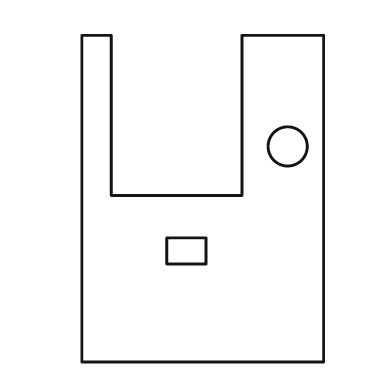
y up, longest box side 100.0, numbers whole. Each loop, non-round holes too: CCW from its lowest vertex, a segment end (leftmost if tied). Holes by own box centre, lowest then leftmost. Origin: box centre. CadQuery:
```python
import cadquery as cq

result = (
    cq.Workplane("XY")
    .moveTo(-37.0, -50.0)
    .lineTo(37.0, -50.0)
    .lineTo(37.0, 50.0)
    .lineTo(12.0, 50.0)
    .lineTo(12.0, 1.0)
    .lineTo(-28.0, 1.0)
    .lineTo(-28.0, 50.0)
    .lineTo(-37.0, 50.0)
    .close()
    .moveTo(-11.0, -20.0)
    .lineTo(1.0, -20.0)
    .lineTo(1.0, -12.0)
    .lineTo(-11.0, -12.0)
    .close()
    .moveTo(26.0, 16.0)
    .circle(6.0)
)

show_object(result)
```